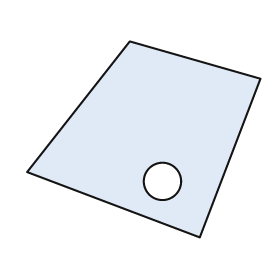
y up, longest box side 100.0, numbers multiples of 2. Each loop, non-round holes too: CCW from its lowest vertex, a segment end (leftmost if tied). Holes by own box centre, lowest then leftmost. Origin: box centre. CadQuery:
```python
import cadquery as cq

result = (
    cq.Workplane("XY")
    .moveTo(24.0, -42.0)
    .lineTo(50.0, 26.0)
    .lineTo(-6.0, 42.0)
    .lineTo(-50.0, -14.0)
    .close()
    .moveTo(8.0, -18.0)
    .circle(8.0)
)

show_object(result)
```